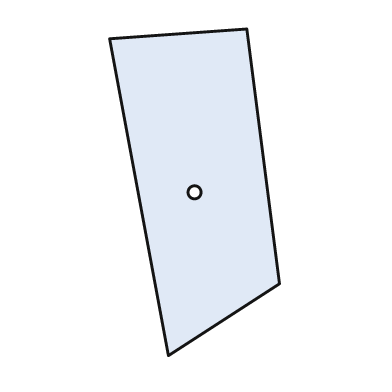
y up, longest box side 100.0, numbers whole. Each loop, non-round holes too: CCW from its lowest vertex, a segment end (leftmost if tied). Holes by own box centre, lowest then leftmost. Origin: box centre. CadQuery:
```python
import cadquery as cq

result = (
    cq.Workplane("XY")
    .moveTo(-8.0, -50.0)
    .lineTo(26.0, -28.0)
    .lineTo(16.0, 50.0)
    .lineTo(-26.0, 47.0)
    .close()
    .moveTo(0.0, 0.0)
    .circle(2.0)
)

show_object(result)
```